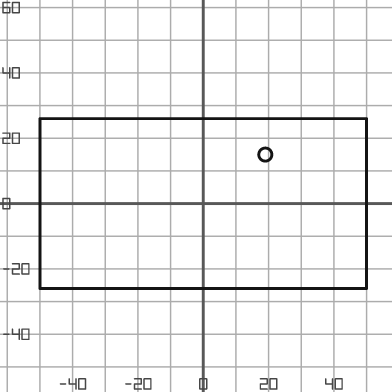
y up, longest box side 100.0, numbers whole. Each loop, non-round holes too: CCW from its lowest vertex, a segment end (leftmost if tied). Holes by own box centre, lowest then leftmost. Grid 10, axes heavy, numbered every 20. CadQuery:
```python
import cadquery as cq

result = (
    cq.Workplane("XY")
    .moveTo(-50.0, -26.0)
    .lineTo(50.0, -26.0)
    .lineTo(50.0, 26.0)
    .lineTo(-50.0, 26.0)
    .close()
    .moveTo(19.0, 15.0)
    .circle(2.0)
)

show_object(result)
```